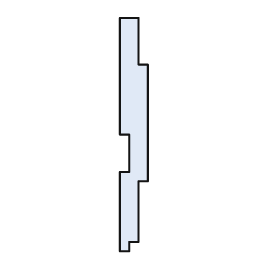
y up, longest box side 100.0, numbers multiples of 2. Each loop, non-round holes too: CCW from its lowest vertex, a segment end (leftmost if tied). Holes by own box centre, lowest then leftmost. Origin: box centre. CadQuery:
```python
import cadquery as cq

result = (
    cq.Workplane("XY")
    .moveTo(-6.0, -50.0)
    .lineTo(-2.0, -50.0)
    .lineTo(-2.0, -46.0)
    .lineTo(2.0, -46.0)
    .lineTo(2.0, -20.0)
    .lineTo(6.0, -20.0)
    .lineTo(6.0, 30.0)
    .lineTo(2.0, 30.0)
    .lineTo(2.0, 50.0)
    .lineTo(-6.0, 50.0)
    .lineTo(-6.0, 0.0)
    .lineTo(-2.0, 0.0)
    .lineTo(-2.0, -16.0)
    .lineTo(-6.0, -16.0)
    .close()
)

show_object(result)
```